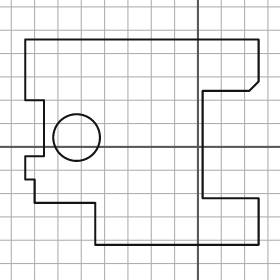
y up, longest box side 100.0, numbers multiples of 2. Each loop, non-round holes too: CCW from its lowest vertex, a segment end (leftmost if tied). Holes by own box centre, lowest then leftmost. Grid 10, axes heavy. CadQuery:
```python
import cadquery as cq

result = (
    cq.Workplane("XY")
    .moveTo(-44.0, -42.0)
    .lineTo(26.0, -42.0)
    .lineTo(26.0, -22.0)
    .lineTo(2.0, -22.0)
    .lineTo(2.0, 24.0)
    .lineTo(22.0, 24.0)
    .lineTo(26.0, 28.0)
    .lineTo(26.0, 46.0)
    .lineTo(-74.0, 46.0)
    .lineTo(-74.0, 20.0)
    .lineTo(-66.0, 20.0)
    .lineTo(-66.0, -4.0)
    .lineTo(-74.0, -4.0)
    .lineTo(-74.0, -14.0)
    .lineTo(-70.0, -14.0)
    .lineTo(-70.0, -24.0)
    .lineTo(-44.0, -24.0)
    .close()
    .moveTo(-52.0, 4.0)
    .circle(10.0)
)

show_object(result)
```